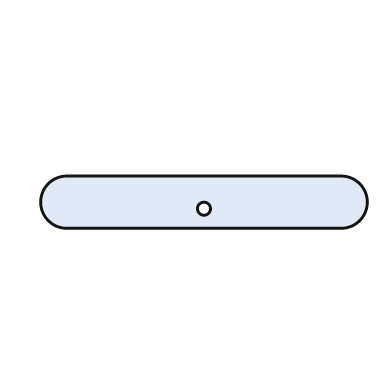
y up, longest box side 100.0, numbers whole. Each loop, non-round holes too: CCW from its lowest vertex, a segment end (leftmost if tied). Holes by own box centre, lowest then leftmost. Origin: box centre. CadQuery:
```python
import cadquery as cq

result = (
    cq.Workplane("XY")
    .moveTo(-42.0, -8.0)
    .lineTo(42.0, -8.0)
    .threePointArc((50.0, 0.0), (42.0, 8.0))
    .lineTo(-42.0, 8.0)
    .threePointArc((-50.0, 0.0), (-42.0, -8.0))
    .close()
    .moveTo(0.0, -2.0)
    .circle(2.0)
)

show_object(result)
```